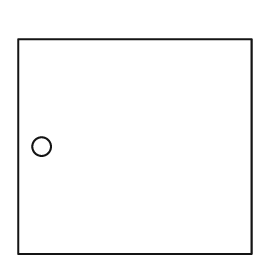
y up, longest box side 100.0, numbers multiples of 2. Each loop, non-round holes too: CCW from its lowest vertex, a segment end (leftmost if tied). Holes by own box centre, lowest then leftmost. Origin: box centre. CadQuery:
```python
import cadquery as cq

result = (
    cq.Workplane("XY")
    .moveTo(-50.0, -46.0)
    .lineTo(50.0, -46.0)
    .lineTo(50.0, 46.0)
    .lineTo(-50.0, 46.0)
    .close()
    .moveTo(-40.0, 0.0)
    .circle(4.0)
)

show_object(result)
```